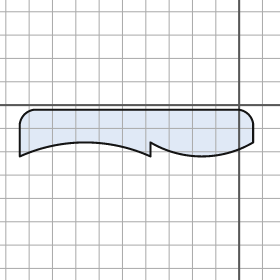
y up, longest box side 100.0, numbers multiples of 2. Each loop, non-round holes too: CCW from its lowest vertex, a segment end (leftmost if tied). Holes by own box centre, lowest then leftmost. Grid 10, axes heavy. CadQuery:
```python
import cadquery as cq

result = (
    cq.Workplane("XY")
    .moveTo(-94.0, -22.0)
    .threePointArc((-66.0, -16.0), (-38.0, -22.0))
    .lineTo(-38.0, -16.0)
    .threePointArc((-16.0, -22.0), (6.0, -16.0))
    .lineTo(6.0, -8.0)
    .threePointArc((4.0, -4.0), (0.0, -2.0))
    .lineTo(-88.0, -2.0)
    .threePointArc((-92.0, -4.0), (-94.0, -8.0))
    .close()
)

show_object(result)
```